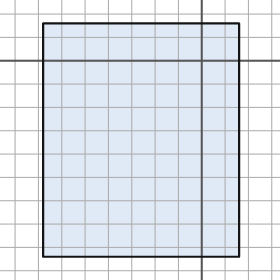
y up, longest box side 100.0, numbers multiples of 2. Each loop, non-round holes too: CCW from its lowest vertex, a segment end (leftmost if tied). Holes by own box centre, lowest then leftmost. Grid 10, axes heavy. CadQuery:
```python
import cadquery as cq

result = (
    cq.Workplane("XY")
    .moveTo(-68.0, -84.0)
    .lineTo(16.0, -84.0)
    .lineTo(16.0, 16.0)
    .lineTo(-68.0, 16.0)
    .close()
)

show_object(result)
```